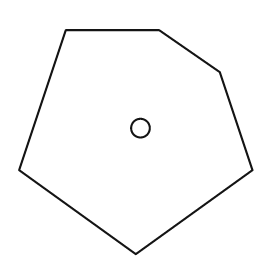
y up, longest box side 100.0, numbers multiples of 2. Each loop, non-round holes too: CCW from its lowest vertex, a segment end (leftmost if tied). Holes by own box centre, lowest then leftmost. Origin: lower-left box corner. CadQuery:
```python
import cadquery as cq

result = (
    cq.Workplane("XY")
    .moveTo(50.0, 0.0)
    .lineTo(100.0, 36.0)
    .lineTo(86.0, 78.0)
    .lineTo(60.0, 96.0)
    .lineTo(20.0, 96.0)
    .lineTo(0.0, 36.0)
    .close()
    .moveTo(52.0, 54.0)
    .circle(4.0)
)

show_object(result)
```